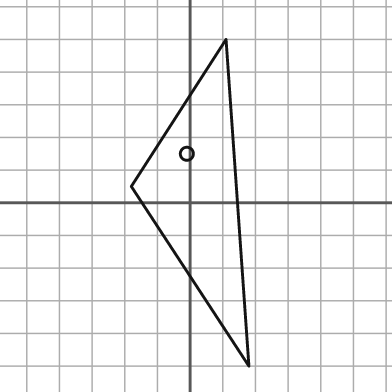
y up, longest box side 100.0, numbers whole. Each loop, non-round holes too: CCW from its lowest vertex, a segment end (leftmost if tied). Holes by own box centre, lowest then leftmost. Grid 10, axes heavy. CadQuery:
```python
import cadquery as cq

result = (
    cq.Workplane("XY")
    .moveTo(18.0, -50.0)
    .lineTo(11.0, 50.0)
    .lineTo(-18.0, 5.0)
    .close()
    .moveTo(-1.0, 15.0)
    .circle(2.0)
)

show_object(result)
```